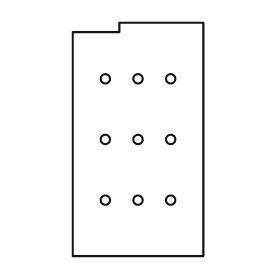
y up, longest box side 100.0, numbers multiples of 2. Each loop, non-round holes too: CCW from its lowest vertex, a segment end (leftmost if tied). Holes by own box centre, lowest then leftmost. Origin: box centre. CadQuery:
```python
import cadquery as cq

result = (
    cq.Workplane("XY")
    .moveTo(-28.0, -50.0)
    .lineTo(28.0, -50.0)
    .lineTo(28.0, 50.0)
    .lineTo(-8.0, 50.0)
    .lineTo(-8.0, 46.0)
    .lineTo(-28.0, 46.0)
    .close()
    .moveTo(-14.0, -26.0)
    .circle(2.0)
    .moveTo(0.0, -26.0)
    .circle(2.0)
    .moveTo(14.0, -26.0)
    .circle(2.0)
    .moveTo(-14.0, 0.0)
    .circle(2.0)
    .moveTo(0.0, 0.0)
    .circle(2.0)
    .moveTo(14.0, 0.0)
    .circle(2.0)
    .moveTo(-14.0, 26.0)
    .circle(2.0)
    .moveTo(0.0, 26.0)
    .circle(2.0)
    .moveTo(14.0, 26.0)
    .circle(2.0)
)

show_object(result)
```